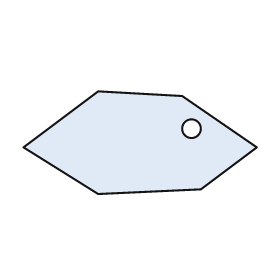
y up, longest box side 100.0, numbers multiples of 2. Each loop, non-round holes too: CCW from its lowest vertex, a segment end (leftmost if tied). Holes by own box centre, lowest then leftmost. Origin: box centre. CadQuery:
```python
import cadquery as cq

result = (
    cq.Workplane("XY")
    .moveTo(-18.0, -22.0)
    .lineTo(26.0, -20.0)
    .lineTo(50.0, -2.0)
    .lineTo(18.0, 20.0)
    .lineTo(-18.0, 22.0)
    .lineTo(-50.0, -2.0)
    .close()
    .moveTo(22.0, 6.0)
    .circle(4.0)
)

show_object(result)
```